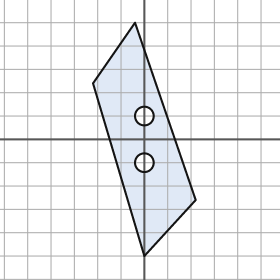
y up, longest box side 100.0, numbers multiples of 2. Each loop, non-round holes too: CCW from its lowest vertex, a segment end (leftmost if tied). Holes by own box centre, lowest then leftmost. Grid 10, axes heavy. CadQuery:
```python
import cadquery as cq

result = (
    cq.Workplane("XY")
    .moveTo(0.0, -50.0)
    .lineTo(22.0, -26.0)
    .lineTo(-4.0, 50.0)
    .lineTo(-22.0, 24.0)
    .close()
    .moveTo(0.0, -10.0)
    .circle(4.0)
    .moveTo(0.0, 10.0)
    .circle(4.0)
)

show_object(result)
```